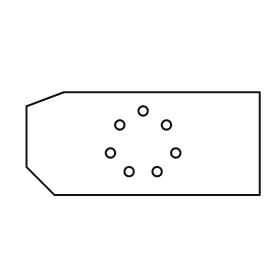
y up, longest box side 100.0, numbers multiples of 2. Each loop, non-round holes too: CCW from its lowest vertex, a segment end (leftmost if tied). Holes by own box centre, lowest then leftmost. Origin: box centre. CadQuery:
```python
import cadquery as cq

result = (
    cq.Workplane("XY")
    .moveTo(-38.0, -22.0)
    .lineTo(50.0, -22.0)
    .lineTo(50.0, 22.0)
    .lineTo(-34.0, 22.0)
    .lineTo(-50.0, 16.0)
    .lineTo(-50.0, -10.0)
    .close()
    .moveTo(-6.0, -12.0)
    .circle(2.0)
    .moveTo(6.0, -12.0)
    .circle(2.0)
    .moveTo(-14.0, -4.0)
    .circle(2.0)
    .moveTo(14.0, -4.0)
    .circle(2.0)
    .moveTo(-10.0, 8.0)
    .circle(2.0)
    .moveTo(10.0, 8.0)
    .circle(2.0)
    .moveTo(0.0, 14.0)
    .circle(2.0)
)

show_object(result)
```